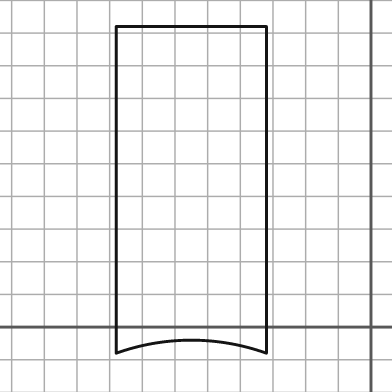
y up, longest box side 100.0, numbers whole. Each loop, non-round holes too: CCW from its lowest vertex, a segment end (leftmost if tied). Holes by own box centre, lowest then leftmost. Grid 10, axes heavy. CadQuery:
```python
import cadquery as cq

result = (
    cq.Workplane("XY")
    .moveTo(-78.0, -8.0)
    .threePointArc((-55.0, -4.0), (-32.0, -8.0))
    .lineTo(-32.0, 92.0)
    .lineTo(-78.0, 92.0)
    .close()
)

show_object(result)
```